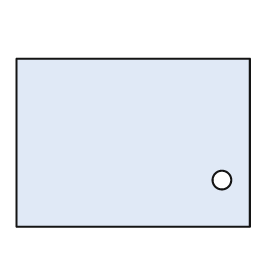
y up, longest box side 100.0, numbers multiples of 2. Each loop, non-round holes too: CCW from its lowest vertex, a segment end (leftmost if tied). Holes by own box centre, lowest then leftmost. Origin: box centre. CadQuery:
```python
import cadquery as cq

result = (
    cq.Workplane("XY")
    .moveTo(-50.0, -36.0)
    .lineTo(50.0, -36.0)
    .lineTo(50.0, 36.0)
    .lineTo(-50.0, 36.0)
    .close()
    .moveTo(38.0, -16.0)
    .circle(4.0)
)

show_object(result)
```